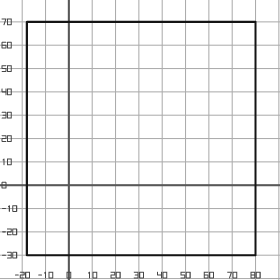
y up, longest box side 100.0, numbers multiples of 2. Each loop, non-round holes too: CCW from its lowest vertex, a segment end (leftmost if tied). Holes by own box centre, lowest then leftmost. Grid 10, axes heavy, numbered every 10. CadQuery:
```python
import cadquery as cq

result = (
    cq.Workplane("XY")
    .moveTo(-18.0, -30.0)
    .lineTo(80.0, -30.0)
    .lineTo(80.0, 70.0)
    .lineTo(-18.0, 70.0)
    .close()
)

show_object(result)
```